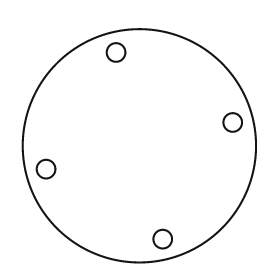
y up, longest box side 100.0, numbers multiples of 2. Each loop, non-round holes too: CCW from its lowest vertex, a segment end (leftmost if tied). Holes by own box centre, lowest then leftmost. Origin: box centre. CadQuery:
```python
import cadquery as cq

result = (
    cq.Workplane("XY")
    .moveTo(0.0, 0.0)
    .circle(50.0)
    .moveTo(10.0, -40.0)
    .circle(4.0)
    .moveTo(-40.0, -10.0)
    .circle(4.0)
    .moveTo(40.0, 10.0)
    .circle(4.0)
    .moveTo(-10.0, 40.0)
    .circle(4.0)
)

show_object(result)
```